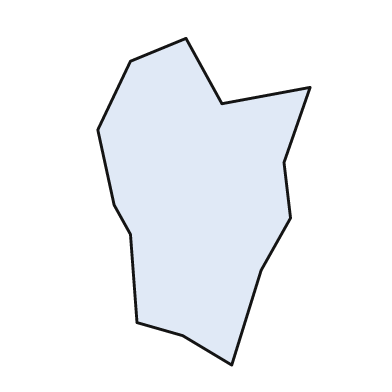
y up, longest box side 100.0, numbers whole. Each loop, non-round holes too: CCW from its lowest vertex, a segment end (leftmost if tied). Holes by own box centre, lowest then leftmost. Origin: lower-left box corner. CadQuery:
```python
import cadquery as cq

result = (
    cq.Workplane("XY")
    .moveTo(41.0, 0.0)
    .lineTo(50.0, 29.0)
    .lineTo(59.0, 45.0)
    .lineTo(57.0, 62.0)
    .lineTo(65.0, 85.0)
    .lineTo(38.0, 80.0)
    .lineTo(27.0, 100.0)
    .lineTo(10.0, 93.0)
    .lineTo(0.0, 72.0)
    .lineTo(5.0, 49.0)
    .lineTo(10.0, 40.0)
    .lineTo(12.0, 13.0)
    .lineTo(26.0, 9.0)
    .close()
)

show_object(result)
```